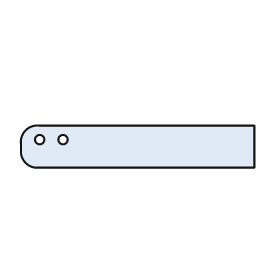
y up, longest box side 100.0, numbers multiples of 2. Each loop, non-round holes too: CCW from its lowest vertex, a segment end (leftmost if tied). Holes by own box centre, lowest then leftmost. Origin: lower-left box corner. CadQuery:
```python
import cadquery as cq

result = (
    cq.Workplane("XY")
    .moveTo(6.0, 0.0)
    .lineTo(100.0, 0.0)
    .lineTo(100.0, 18.0)
    .lineTo(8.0, 18.0)
    .threePointArc((2.0, 16.0), (0.0, 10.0))
    .lineTo(0.0, 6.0)
    .threePointArc((2.0, 2.0), (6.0, 0.0))
    .close()
    .moveTo(8.0, 12.0)
    .circle(2.0)
    .moveTo(18.0, 12.0)
    .circle(2.0)
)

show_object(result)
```